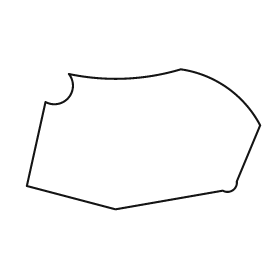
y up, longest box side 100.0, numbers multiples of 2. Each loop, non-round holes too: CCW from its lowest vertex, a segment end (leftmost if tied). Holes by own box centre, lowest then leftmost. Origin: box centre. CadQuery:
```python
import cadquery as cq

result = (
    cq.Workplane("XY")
    .moveTo(-12.0, -30.0)
    .lineTo(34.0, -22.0)
    .threePointArc((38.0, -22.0), (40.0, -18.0))
    .lineTo(50.0, 6.0)
    .threePointArc((36.0, 22.0), (16.0, 30.0))
    .threePointArc((-8.0, 26.0), (-32.0, 28.0))
    .threePointArc((-32.0, 18.0), (-42.0, 16.0))
    .lineTo(-50.0, -20.0)
    .close()
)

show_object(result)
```